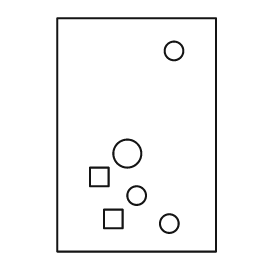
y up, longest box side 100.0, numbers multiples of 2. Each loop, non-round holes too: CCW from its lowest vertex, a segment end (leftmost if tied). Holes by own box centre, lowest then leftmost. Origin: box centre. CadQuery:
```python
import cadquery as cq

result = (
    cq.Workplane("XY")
    .moveTo(-34.0, -50.0)
    .lineTo(34.0, -50.0)
    .lineTo(34.0, 50.0)
    .lineTo(-34.0, 50.0)
    .close()
    .moveTo(14.0, -38.0)
    .circle(4.0)
    .moveTo(-14.0, -40.0)
    .lineTo(-6.0, -40.0)
    .lineTo(-6.0, -32.0)
    .lineTo(-14.0, -32.0)
    .close()
    .moveTo(0.0, -26.0)
    .circle(4.0)
    .moveTo(-20.0, -22.0)
    .lineTo(-12.0, -22.0)
    .lineTo(-12.0, -14.0)
    .lineTo(-20.0, -14.0)
    .close()
    .moveTo(-4.0, -8.0)
    .circle(6.0)
    .moveTo(16.0, 36.0)
    .circle(4.0)
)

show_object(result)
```